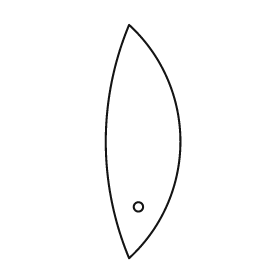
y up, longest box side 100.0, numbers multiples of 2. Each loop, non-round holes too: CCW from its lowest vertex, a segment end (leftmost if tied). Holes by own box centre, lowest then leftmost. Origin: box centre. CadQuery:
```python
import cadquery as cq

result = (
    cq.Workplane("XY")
    .moveTo(-6.0, -50.0)
    .threePointArc((16.0, 0.0), (-6.0, 50.0))
    .threePointArc((-16.0, 0.0), (-6.0, -50.0))
    .close()
    .moveTo(-2.0, -28.0)
    .circle(2.0)
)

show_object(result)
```